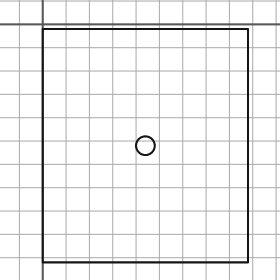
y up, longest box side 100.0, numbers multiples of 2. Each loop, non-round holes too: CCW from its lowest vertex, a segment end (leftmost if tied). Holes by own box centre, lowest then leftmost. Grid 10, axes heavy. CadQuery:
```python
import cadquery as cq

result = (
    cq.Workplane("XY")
    .moveTo(0.0, -102.0)
    .lineTo(88.0, -102.0)
    .lineTo(88.0, -2.0)
    .lineTo(0.0, -2.0)
    .close()
    .moveTo(44.0, -52.0)
    .circle(4.0)
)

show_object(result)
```